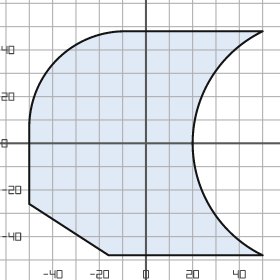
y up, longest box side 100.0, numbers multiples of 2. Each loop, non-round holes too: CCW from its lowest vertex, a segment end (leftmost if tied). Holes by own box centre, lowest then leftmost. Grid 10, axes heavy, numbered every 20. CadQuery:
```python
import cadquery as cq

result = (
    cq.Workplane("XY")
    .moveTo(-16.0, -48.0)
    .lineTo(50.0, -48.0)
    .threePointArc((20.0, 0.0), (50.0, 48.0))
    .lineTo(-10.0, 48.0)
    .threePointArc((-38.0, 36.0), (-50.0, 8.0))
    .lineTo(-50.0, -26.0)
    .close()
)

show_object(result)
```